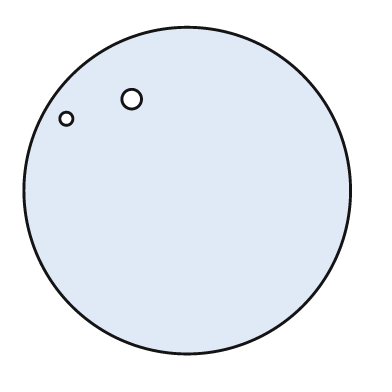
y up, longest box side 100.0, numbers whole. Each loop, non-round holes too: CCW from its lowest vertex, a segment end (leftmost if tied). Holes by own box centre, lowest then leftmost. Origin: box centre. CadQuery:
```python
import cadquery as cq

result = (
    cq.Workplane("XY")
    .moveTo(0.0, 0.0)
    .circle(50.0)
    .moveTo(-37.0, 22.0)
    .circle(2.0)
    .moveTo(-17.0, 28.0)
    .circle(3.0)
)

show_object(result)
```